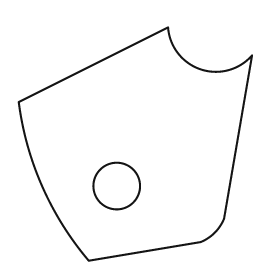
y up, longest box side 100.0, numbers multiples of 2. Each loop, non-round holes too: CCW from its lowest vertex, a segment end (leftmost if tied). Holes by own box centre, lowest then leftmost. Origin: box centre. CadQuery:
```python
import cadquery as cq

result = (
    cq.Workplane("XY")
    .moveTo(-20.0, -50.0)
    .lineTo(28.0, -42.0)
    .threePointArc((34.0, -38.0), (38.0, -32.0))
    .lineTo(50.0, 38.0)
    .threePointArc((28.0, 32.0), (14.0, 50.0))
    .lineTo(-50.0, 18.0)
    .threePointArc((-40.0, -18.0), (-20.0, -50.0))
    .close()
    .moveTo(-8.0, -18.0)
    .circle(10.0)
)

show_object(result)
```